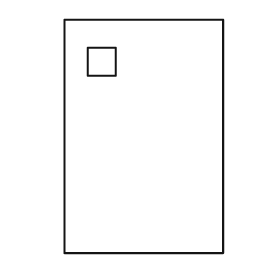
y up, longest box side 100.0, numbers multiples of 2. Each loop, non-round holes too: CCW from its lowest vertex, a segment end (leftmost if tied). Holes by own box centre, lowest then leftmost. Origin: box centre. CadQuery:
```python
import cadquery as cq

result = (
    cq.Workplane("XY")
    .moveTo(-34.0, -50.0)
    .lineTo(34.0, -50.0)
    .lineTo(34.0, 50.0)
    .lineTo(-34.0, 50.0)
    .close()
    .moveTo(-24.0, 26.0)
    .lineTo(-12.0, 26.0)
    .lineTo(-12.0, 38.0)
    .lineTo(-24.0, 38.0)
    .close()
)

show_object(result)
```